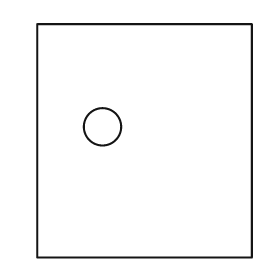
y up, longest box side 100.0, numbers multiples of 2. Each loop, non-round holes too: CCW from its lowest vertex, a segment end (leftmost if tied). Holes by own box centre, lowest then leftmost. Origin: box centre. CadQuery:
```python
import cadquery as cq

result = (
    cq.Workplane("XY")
    .moveTo(-46.0, -50.0)
    .lineTo(46.0, -50.0)
    .lineTo(46.0, 50.0)
    .lineTo(-46.0, 50.0)
    .close()
    .moveTo(-18.0, 6.0)
    .circle(8.0)
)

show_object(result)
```